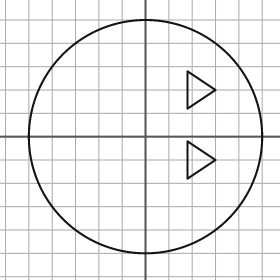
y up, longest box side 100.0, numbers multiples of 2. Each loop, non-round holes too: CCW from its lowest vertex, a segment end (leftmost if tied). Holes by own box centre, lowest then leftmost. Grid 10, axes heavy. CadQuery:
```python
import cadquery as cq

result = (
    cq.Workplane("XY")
    .moveTo(0.0, 0.0)
    .circle(50.0)
    .moveTo(18.0, -18.0)
    .lineTo(30.0, -10.0)
    .lineTo(18.0, -2.0)
    .close()
    .moveTo(18.0, 12.0)
    .lineTo(30.0, 20.0)
    .lineTo(18.0, 28.0)
    .close()
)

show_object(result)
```